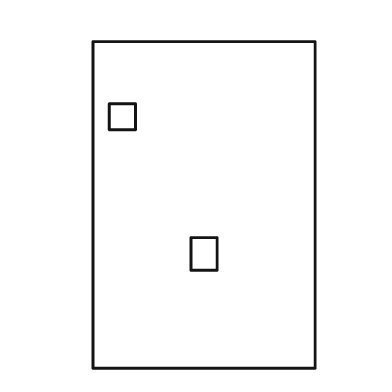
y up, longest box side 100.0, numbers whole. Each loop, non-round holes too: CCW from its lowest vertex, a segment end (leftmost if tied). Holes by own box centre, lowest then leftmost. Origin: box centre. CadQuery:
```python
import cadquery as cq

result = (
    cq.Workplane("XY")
    .moveTo(-34.0, -50.0)
    .lineTo(34.0, -50.0)
    .lineTo(34.0, 50.0)
    .lineTo(-34.0, 50.0)
    .close()
    .moveTo(-4.0, -20.0)
    .lineTo(4.0, -20.0)
    .lineTo(4.0, -10.0)
    .lineTo(-4.0, -10.0)
    .close()
    .moveTo(-29.0, 23.0)
    .lineTo(-21.0, 23.0)
    .lineTo(-21.0, 31.0)
    .lineTo(-29.0, 31.0)
    .close()
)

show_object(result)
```